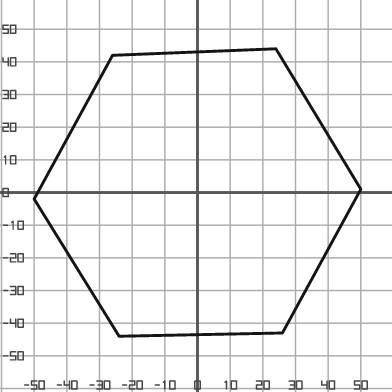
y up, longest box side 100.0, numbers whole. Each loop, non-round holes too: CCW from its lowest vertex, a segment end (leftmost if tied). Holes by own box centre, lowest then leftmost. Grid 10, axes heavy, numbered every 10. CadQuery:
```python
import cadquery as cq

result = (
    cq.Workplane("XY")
    .moveTo(-24.0, -44.0)
    .lineTo(26.0, -43.0)
    .lineTo(50.0, 1.0)
    .lineTo(24.0, 44.0)
    .lineTo(-26.0, 42.0)
    .lineTo(-50.0, -2.0)
    .close()
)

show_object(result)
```